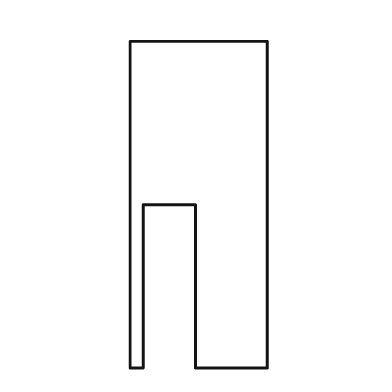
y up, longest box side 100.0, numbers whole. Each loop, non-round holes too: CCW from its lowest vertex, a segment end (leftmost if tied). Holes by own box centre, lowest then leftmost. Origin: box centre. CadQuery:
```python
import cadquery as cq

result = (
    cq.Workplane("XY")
    .moveTo(-21.0, -50.0)
    .lineTo(-17.0, -50.0)
    .lineTo(-17.0, 0.0)
    .lineTo(-1.0, 0.0)
    .lineTo(-1.0, -50.0)
    .lineTo(21.0, -50.0)
    .lineTo(21.0, 50.0)
    .lineTo(-21.0, 50.0)
    .close()
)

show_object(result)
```